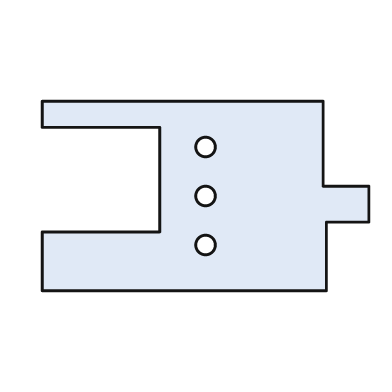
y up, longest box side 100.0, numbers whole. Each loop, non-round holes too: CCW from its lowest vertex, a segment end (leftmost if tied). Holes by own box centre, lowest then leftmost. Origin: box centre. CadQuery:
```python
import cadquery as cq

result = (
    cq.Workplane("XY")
    .moveTo(-50.0, -29.0)
    .lineTo(37.0, -29.0)
    .lineTo(37.0, -8.0)
    .lineTo(50.0, -8.0)
    .lineTo(50.0, 3.0)
    .lineTo(36.0, 3.0)
    .lineTo(36.0, 29.0)
    .lineTo(-50.0, 29.0)
    .lineTo(-50.0, 21.0)
    .lineTo(-14.0, 21.0)
    .lineTo(-14.0, -11.0)
    .lineTo(-50.0, -11.0)
    .close()
    .moveTo(0.0, -15.0)
    .circle(3.0)
    .moveTo(0.0, 0.0)
    .circle(3.0)
    .moveTo(0.0, 15.0)
    .circle(3.0)
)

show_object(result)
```